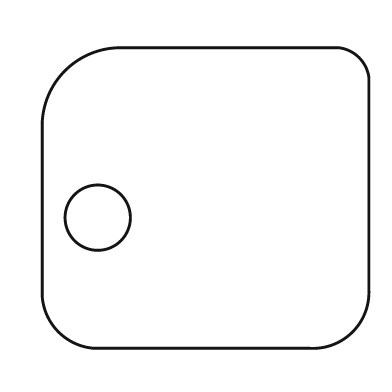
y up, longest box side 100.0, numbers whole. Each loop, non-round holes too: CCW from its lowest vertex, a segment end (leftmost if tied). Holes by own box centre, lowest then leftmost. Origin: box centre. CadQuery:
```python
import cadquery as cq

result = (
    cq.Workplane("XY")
    .moveTo(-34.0, -46.0)
    .lineTo(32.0, -46.0)
    .threePointArc((45.0, -41.0), (50.0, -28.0))
    .lineTo(50.0, 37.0)
    .threePointArc((47.0, 43.0), (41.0, 46.0))
    .lineTo(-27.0, 46.0)
    .threePointArc((-43.0, 39.0), (-50.0, 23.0))
    .lineTo(-50.0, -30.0)
    .threePointArc((-45.0, -41.0), (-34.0, -46.0))
    .close()
    .moveTo(-33.0, -6.0)
    .circle(10.0)
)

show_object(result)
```